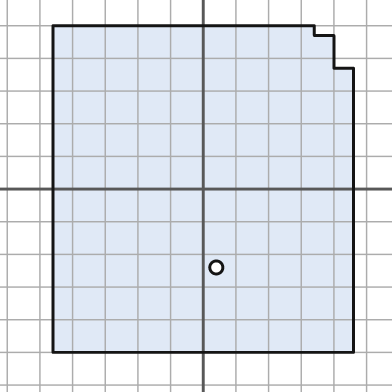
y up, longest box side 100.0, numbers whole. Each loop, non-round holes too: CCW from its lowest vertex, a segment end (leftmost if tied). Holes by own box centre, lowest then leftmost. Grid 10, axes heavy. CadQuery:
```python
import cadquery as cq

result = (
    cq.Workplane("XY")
    .moveTo(-46.0, -50.0)
    .lineTo(46.0, -50.0)
    .lineTo(46.0, 37.0)
    .lineTo(40.0, 37.0)
    .lineTo(40.0, 47.0)
    .lineTo(34.0, 47.0)
    .lineTo(34.0, 50.0)
    .lineTo(-46.0, 50.0)
    .close()
    .moveTo(4.0, -24.0)
    .circle(2.0)
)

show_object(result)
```